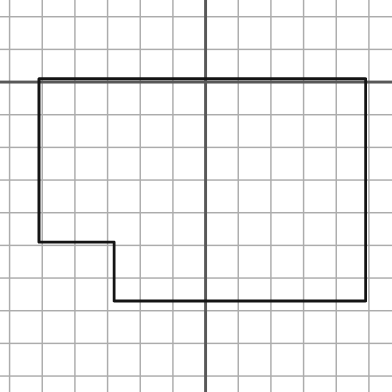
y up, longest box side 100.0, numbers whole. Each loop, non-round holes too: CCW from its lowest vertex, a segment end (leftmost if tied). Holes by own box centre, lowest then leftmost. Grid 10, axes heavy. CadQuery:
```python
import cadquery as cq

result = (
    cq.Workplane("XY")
    .moveTo(-28.0, -67.0)
    .lineTo(49.0, -67.0)
    .lineTo(49.0, 1.0)
    .lineTo(-51.0, 1.0)
    .lineTo(-51.0, -49.0)
    .lineTo(-28.0, -49.0)
    .close()
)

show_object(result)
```